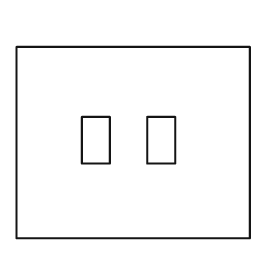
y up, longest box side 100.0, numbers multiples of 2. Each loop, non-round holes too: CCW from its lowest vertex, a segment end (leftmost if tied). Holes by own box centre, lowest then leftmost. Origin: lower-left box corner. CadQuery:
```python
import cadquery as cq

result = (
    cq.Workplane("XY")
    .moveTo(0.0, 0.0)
    .lineTo(100.0, 0.0)
    .lineTo(100.0, 82.0)
    .lineTo(0.0, 82.0)
    .close()
    .moveTo(28.0, 32.0)
    .lineTo(40.0, 32.0)
    .lineTo(40.0, 52.0)
    .lineTo(28.0, 52.0)
    .close()
    .moveTo(56.0, 32.0)
    .lineTo(68.0, 32.0)
    .lineTo(68.0, 52.0)
    .lineTo(56.0, 52.0)
    .close()
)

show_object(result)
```